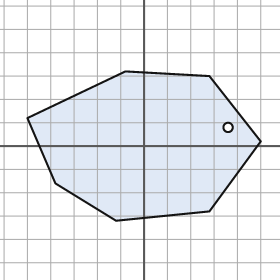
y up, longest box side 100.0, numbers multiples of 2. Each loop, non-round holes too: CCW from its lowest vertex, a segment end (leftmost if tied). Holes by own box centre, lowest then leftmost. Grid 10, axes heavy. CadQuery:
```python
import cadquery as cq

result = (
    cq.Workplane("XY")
    .moveTo(-12.0, -32.0)
    .lineTo(28.0, -28.0)
    .lineTo(50.0, 2.0)
    .lineTo(28.0, 30.0)
    .lineTo(-8.0, 32.0)
    .lineTo(-50.0, 12.0)
    .lineTo(-38.0, -16.0)
    .close()
    .moveTo(36.0, 8.0)
    .circle(2.0)
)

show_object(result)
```